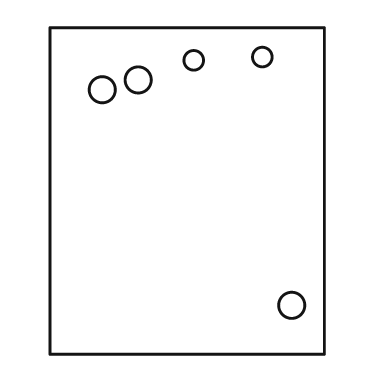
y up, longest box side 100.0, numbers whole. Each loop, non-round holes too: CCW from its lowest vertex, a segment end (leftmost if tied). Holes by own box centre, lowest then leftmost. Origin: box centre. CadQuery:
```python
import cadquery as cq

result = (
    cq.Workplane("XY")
    .moveTo(-42.0, -50.0)
    .lineTo(42.0, -50.0)
    .lineTo(42.0, 50.0)
    .lineTo(-42.0, 50.0)
    .close()
    .moveTo(32.0, -35.0)
    .circle(4.0)
    .moveTo(-26.0, 31.0)
    .circle(4.0)
    .moveTo(-15.0, 34.0)
    .circle(4.0)
    .moveTo(2.0, 40.0)
    .circle(3.0)
    .moveTo(23.0, 41.0)
    .circle(3.0)
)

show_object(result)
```